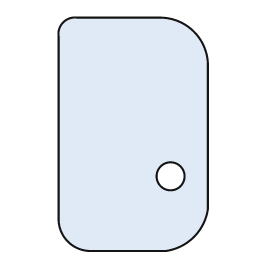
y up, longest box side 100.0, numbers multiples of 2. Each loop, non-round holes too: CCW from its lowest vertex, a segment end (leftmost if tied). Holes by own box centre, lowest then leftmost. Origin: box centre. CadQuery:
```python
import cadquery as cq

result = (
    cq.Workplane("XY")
    .moveTo(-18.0, -50.0)
    .lineTo(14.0, -50.0)
    .threePointArc((26.0, -44.0), (32.0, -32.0))
    .lineTo(32.0, 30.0)
    .threePointArc((26.0, 44.0), (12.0, 50.0))
    .lineTo(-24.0, 50.0)
    .threePointArc((-30.0, 48.0), (-32.0, 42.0))
    .lineTo(-32.0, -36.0)
    .threePointArc((-28.0, -46.0), (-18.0, -50.0))
    .close()
    .moveTo(16.0, -18.0)
    .circle(6.0)
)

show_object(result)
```